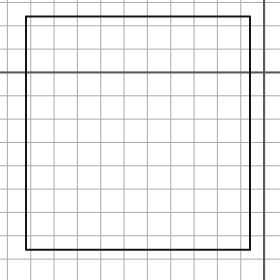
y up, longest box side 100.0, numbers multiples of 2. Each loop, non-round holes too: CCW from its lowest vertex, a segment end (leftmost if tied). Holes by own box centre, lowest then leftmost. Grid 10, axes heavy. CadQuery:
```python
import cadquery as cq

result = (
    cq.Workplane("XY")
    .moveTo(-102.0, -76.0)
    .lineTo(-6.0, -76.0)
    .lineTo(-6.0, 24.0)
    .lineTo(-102.0, 24.0)
    .close()
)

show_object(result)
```